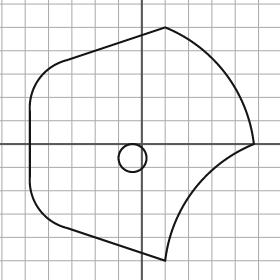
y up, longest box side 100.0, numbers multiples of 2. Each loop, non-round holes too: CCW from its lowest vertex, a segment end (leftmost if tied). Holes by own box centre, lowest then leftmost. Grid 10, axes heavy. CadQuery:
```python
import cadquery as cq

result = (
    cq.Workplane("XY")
    .moveTo(10.0, -50.0)
    .threePointArc((22.0, -20.0), (48.0, 0.0))
    .threePointArc((36.0, 30.0), (10.0, 50.0))
    .lineTo(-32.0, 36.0)
    .threePointArc((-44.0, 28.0), (-48.0, 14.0))
    .lineTo(-48.0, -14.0)
    .threePointArc((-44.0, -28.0), (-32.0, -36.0))
    .close()
    .moveTo(-4.0, -6.0)
    .circle(6.0)
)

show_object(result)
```